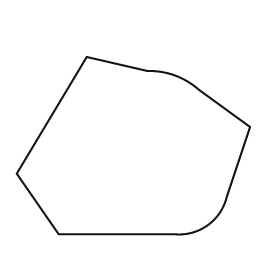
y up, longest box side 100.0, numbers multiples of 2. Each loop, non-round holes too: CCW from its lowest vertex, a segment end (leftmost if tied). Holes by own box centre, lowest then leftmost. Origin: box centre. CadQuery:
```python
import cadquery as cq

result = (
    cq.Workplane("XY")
    .moveTo(-32.0, -38.0)
    .lineTo(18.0, -38.0)
    .threePointArc((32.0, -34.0), (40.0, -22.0))
    .lineTo(50.0, 8.0)
    .lineTo(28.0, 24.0)
    .threePointArc((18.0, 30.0), (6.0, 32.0))
    .lineTo(-20.0, 38.0)
    .lineTo(-50.0, -12.0)
    .close()
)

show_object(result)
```